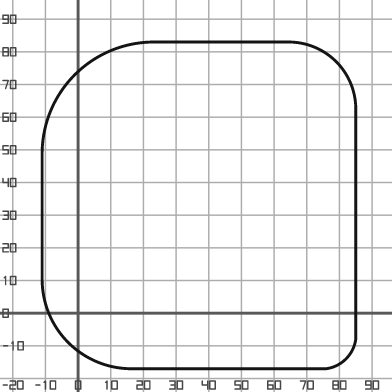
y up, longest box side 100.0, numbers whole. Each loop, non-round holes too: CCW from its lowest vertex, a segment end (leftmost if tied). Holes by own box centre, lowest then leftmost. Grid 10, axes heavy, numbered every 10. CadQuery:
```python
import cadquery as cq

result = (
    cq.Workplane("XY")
    .moveTo(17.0, -17.0)
    .lineTo(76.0, -17.0)
    .threePointArc((82.0, -14.0), (85.0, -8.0))
    .lineTo(85.0, 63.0)
    .threePointArc((79.0, 77.0), (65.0, 83.0))
    .lineTo(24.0, 83.0)
    .threePointArc((-1.0, 73.0), (-11.0, 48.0))
    .lineTo(-11.0, 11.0)
    .threePointArc((-3.0, -9.0), (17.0, -17.0))
    .close()
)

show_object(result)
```